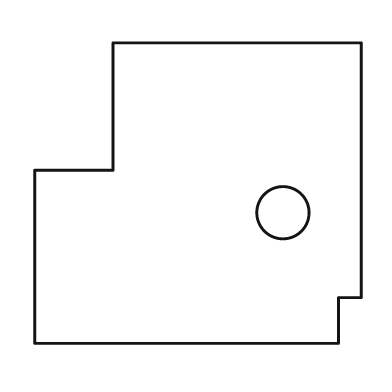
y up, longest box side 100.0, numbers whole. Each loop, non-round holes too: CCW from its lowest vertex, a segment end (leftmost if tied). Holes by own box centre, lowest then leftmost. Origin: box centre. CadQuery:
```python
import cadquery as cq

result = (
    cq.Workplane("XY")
    .moveTo(-50.0, -46.0)
    .lineTo(43.0, -46.0)
    .lineTo(43.0, -32.0)
    .lineTo(50.0, -32.0)
    .lineTo(50.0, 46.0)
    .lineTo(-26.0, 46.0)
    .lineTo(-26.0, 7.0)
    .lineTo(-50.0, 7.0)
    .close()
    .moveTo(26.0, -6.0)
    .circle(8.0)
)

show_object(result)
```